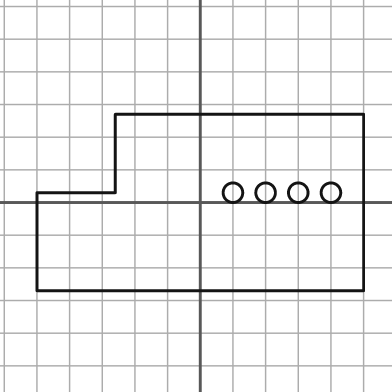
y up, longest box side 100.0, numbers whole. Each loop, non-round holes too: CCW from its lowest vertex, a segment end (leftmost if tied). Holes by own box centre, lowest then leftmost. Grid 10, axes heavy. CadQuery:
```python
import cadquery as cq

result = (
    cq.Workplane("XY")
    .moveTo(-50.0, -27.0)
    .lineTo(50.0, -27.0)
    .lineTo(50.0, 27.0)
    .lineTo(-26.0, 27.0)
    .lineTo(-26.0, 3.0)
    .lineTo(-50.0, 3.0)
    .close()
    .moveTo(10.0, 3.0)
    .circle(3.0)
    .moveTo(20.0, 3.0)
    .circle(3.0)
    .moveTo(30.0, 3.0)
    .circle(3.0)
    .moveTo(40.0, 3.0)
    .circle(3.0)
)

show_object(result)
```